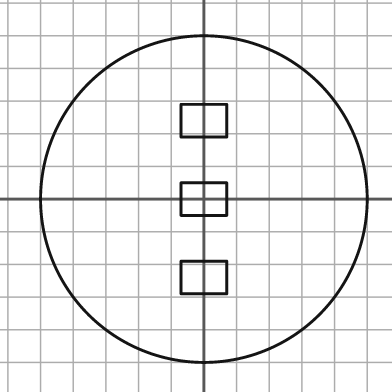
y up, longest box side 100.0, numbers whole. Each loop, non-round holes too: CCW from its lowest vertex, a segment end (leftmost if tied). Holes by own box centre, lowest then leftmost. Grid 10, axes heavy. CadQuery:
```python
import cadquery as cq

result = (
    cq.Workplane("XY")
    .moveTo(0.0, 0.0)
    .circle(50.0)
    .moveTo(-7.0, -29.0)
    .lineTo(7.0, -29.0)
    .lineTo(7.0, -19.0)
    .lineTo(-7.0, -19.0)
    .close()
    .moveTo(-7.0, -5.0)
    .lineTo(7.0, -5.0)
    .lineTo(7.0, 5.0)
    .lineTo(-7.0, 5.0)
    .close()
    .moveTo(-7.0, 19.0)
    .lineTo(7.0, 19.0)
    .lineTo(7.0, 29.0)
    .lineTo(-7.0, 29.0)
    .close()
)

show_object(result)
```